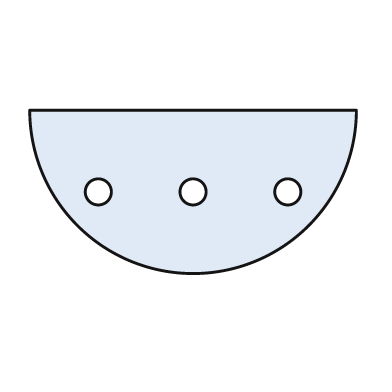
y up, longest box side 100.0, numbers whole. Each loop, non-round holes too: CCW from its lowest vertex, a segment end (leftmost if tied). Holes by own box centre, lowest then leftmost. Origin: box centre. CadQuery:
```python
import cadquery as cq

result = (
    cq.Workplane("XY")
    .moveTo(-50.0, 25.0)
    .threePointArc((0.0, -25.0), (50.0, 25.0))
    .close()
    .moveTo(-29.0, 0.0)
    .circle(4.0)
    .moveTo(0.0, 0.0)
    .circle(4.0)
    .moveTo(29.0, 0.0)
    .circle(4.0)
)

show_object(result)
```